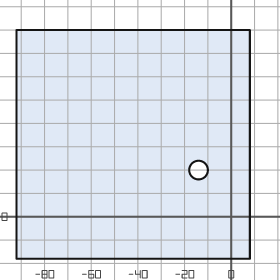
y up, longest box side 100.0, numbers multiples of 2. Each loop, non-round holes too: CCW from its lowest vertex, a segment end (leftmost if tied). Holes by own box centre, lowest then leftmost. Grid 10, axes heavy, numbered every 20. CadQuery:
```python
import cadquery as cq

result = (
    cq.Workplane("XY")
    .moveTo(-92.0, -18.0)
    .lineTo(8.0, -18.0)
    .lineTo(8.0, 80.0)
    .lineTo(-92.0, 80.0)
    .close()
    .moveTo(-14.0, 20.0)
    .circle(4.0)
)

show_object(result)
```